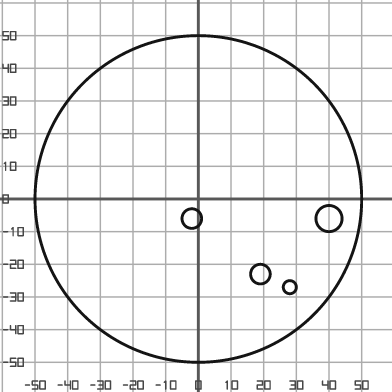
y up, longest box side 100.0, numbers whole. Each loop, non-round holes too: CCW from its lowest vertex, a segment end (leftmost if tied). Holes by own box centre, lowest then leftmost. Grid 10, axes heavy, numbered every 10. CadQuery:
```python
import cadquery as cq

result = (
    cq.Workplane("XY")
    .moveTo(0.0, 0.0)
    .circle(50.0)
    .moveTo(28.0, -27.0)
    .circle(2.0)
    .moveTo(19.0, -23.0)
    .circle(3.0)
    .moveTo(-2.0, -6.0)
    .circle(3.0)
    .moveTo(40.0, -6.0)
    .circle(4.0)
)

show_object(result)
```